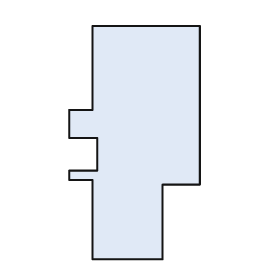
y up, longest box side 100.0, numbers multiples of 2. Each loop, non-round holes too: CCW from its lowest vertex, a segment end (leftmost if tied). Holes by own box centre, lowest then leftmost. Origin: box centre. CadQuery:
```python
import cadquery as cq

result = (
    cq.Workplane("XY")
    .moveTo(-18.0, -50.0)
    .lineTo(12.0, -50.0)
    .lineTo(12.0, -18.0)
    .lineTo(28.0, -18.0)
    .lineTo(28.0, 50.0)
    .lineTo(-18.0, 50.0)
    .lineTo(-18.0, 14.0)
    .lineTo(-28.0, 14.0)
    .lineTo(-28.0, 2.0)
    .lineTo(-16.0, 2.0)
    .lineTo(-16.0, -12.0)
    .lineTo(-28.0, -12.0)
    .lineTo(-28.0, -16.0)
    .lineTo(-18.0, -16.0)
    .close()
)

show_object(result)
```